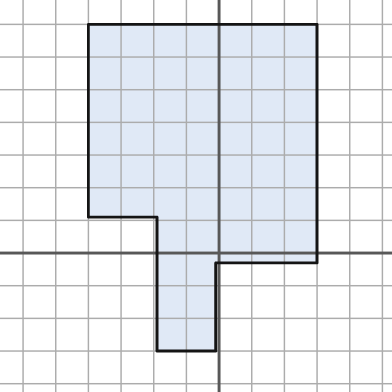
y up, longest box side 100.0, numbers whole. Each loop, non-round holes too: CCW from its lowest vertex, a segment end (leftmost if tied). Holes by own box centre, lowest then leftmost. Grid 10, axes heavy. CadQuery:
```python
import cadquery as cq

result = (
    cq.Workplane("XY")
    .moveTo(-19.0, -30.0)
    .lineTo(-1.0, -30.0)
    .lineTo(-1.0, -3.0)
    .lineTo(30.0, -3.0)
    .lineTo(30.0, 70.0)
    .lineTo(-40.0, 70.0)
    .lineTo(-40.0, 11.0)
    .lineTo(-19.0, 11.0)
    .close()
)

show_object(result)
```